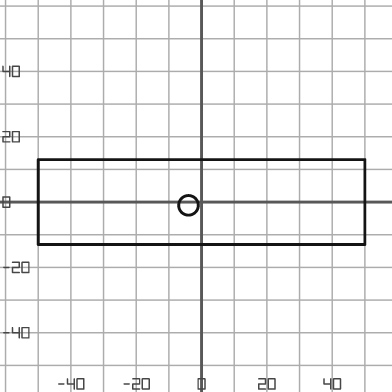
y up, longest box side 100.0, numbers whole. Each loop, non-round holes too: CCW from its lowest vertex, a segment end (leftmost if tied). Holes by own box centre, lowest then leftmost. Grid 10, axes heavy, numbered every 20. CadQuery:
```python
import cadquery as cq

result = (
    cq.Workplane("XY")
    .moveTo(-50.0, -13.0)
    .lineTo(50.0, -13.0)
    .lineTo(50.0, 13.0)
    .lineTo(-50.0, 13.0)
    .close()
    .moveTo(-4.0, -1.0)
    .circle(3.0)
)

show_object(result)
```